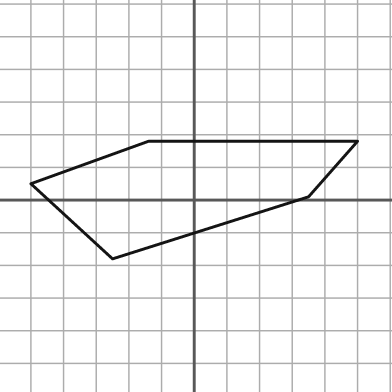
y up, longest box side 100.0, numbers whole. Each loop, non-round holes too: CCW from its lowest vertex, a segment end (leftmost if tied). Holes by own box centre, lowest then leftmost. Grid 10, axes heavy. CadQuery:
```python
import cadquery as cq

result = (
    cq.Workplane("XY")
    .moveTo(-25.0, -18.0)
    .lineTo(35.0, 1.0)
    .lineTo(50.0, 18.0)
    .lineTo(-14.0, 18.0)
    .lineTo(-50.0, 5.0)
    .close()
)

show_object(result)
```